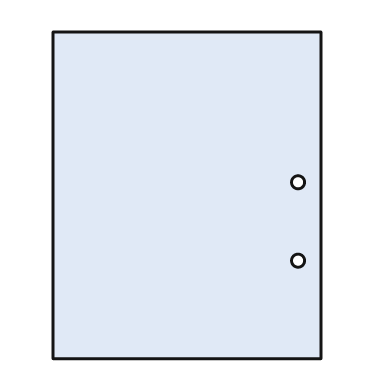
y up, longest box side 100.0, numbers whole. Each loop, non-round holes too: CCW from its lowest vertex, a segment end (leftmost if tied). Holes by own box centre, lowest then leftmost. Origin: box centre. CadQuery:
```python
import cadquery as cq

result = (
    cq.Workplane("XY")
    .moveTo(-41.0, -50.0)
    .lineTo(41.0, -50.0)
    .lineTo(41.0, 50.0)
    .lineTo(-41.0, 50.0)
    .close()
    .moveTo(34.0, -20.0)
    .circle(2.0)
    .moveTo(34.0, 4.0)
    .circle(2.0)
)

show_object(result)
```